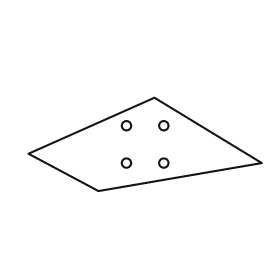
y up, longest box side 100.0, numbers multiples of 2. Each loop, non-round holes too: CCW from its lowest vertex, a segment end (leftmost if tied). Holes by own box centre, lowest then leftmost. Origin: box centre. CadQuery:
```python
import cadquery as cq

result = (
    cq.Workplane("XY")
    .moveTo(-20.0, -20.0)
    .lineTo(50.0, -8.0)
    .lineTo(4.0, 20.0)
    .lineTo(-50.0, -4.0)
    .close()
    .moveTo(-8.0, -8.0)
    .circle(2.0)
    .moveTo(8.0, -8.0)
    .circle(2.0)
    .moveTo(-8.0, 8.0)
    .circle(2.0)
    .moveTo(8.0, 8.0)
    .circle(2.0)
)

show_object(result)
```